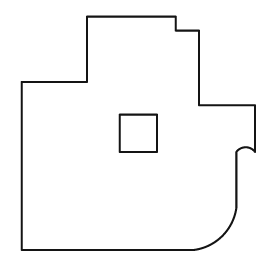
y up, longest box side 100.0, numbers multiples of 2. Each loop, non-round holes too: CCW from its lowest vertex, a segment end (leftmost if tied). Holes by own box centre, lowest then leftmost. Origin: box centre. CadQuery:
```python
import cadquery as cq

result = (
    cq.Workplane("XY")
    .moveTo(-50.0, -50.0)
    .lineTo(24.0, -50.0)
    .threePointArc((36.0, -44.0), (42.0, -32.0))
    .lineTo(42.0, -8.0)
    .threePointArc((46.0, -6.0), (50.0, -8.0))
    .lineTo(50.0, 12.0)
    .lineTo(26.0, 12.0)
    .lineTo(26.0, 44.0)
    .lineTo(16.0, 44.0)
    .lineTo(16.0, 50.0)
    .lineTo(-22.0, 50.0)
    .lineTo(-22.0, 22.0)
    .lineTo(-50.0, 22.0)
    .close()
    .moveTo(-8.0, -8.0)
    .lineTo(8.0, -8.0)
    .lineTo(8.0, 8.0)
    .lineTo(-8.0, 8.0)
    .close()
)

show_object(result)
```